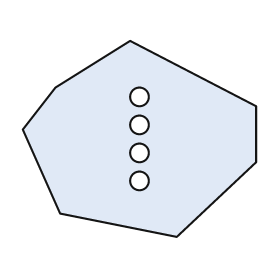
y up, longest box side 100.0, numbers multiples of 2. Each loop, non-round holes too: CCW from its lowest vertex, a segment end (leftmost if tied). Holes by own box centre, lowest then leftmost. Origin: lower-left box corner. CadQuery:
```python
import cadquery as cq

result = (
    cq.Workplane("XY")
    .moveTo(66.0, 0.0)
    .lineTo(100.0, 32.0)
    .lineTo(100.0, 56.0)
    .lineTo(46.0, 84.0)
    .lineTo(14.0, 64.0)
    .lineTo(0.0, 46.0)
    .lineTo(16.0, 10.0)
    .close()
    .moveTo(50.0, 24.0)
    .circle(4.0)
    .moveTo(50.0, 36.0)
    .circle(4.0)
    .moveTo(50.0, 48.0)
    .circle(4.0)
    .moveTo(50.0, 60.0)
    .circle(4.0)
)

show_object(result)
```